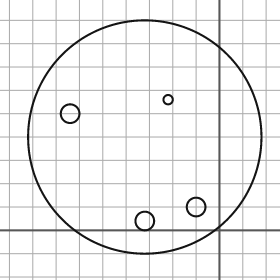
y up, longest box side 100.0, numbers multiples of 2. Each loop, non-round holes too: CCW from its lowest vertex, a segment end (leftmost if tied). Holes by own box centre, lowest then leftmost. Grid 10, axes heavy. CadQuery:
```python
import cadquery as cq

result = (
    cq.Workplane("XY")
    .moveTo(-32.0, 40.0)
    .circle(50.0)
    .moveTo(-32.0, 4.0)
    .circle(4.0)
    .moveTo(-10.0, 10.0)
    .circle(4.0)
    .moveTo(-64.0, 50.0)
    .circle(4.0)
    .moveTo(-22.0, 56.0)
    .circle(2.0)
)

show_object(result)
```